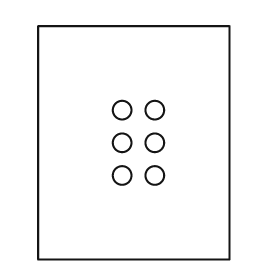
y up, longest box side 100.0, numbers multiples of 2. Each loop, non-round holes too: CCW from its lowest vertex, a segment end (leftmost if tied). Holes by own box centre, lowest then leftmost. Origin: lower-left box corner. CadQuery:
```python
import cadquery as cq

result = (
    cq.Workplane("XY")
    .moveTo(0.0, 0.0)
    .lineTo(82.0, 0.0)
    .lineTo(82.0, 100.0)
    .lineTo(0.0, 100.0)
    .close()
    .moveTo(36.0, 36.0)
    .circle(4.0)
    .moveTo(50.0, 36.0)
    .circle(4.0)
    .moveTo(36.0, 50.0)
    .circle(4.0)
    .moveTo(50.0, 50.0)
    .circle(4.0)
    .moveTo(36.0, 64.0)
    .circle(4.0)
    .moveTo(50.0, 64.0)
    .circle(4.0)
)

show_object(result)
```